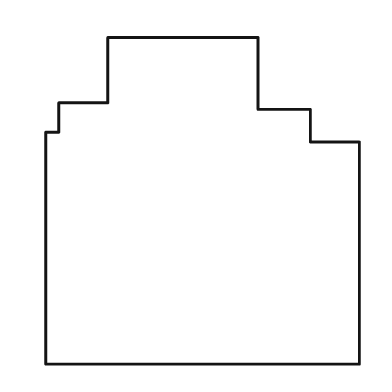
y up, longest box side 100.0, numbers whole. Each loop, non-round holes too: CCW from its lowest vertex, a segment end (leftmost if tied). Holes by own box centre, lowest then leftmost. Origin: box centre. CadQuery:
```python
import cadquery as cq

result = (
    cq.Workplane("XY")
    .moveTo(-48.0, -50.0)
    .lineTo(48.0, -50.0)
    .lineTo(48.0, 18.0)
    .lineTo(33.0, 18.0)
    .lineTo(33.0, 28.0)
    .lineTo(17.0, 28.0)
    .lineTo(17.0, 50.0)
    .lineTo(-29.0, 50.0)
    .lineTo(-29.0, 30.0)
    .lineTo(-44.0, 30.0)
    .lineTo(-44.0, 21.0)
    .lineTo(-48.0, 21.0)
    .close()
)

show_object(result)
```